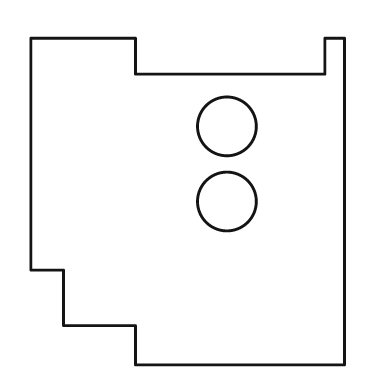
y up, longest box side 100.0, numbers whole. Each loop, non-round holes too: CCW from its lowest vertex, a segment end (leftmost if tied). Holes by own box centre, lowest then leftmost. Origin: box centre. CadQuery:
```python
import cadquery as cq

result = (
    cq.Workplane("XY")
    .moveTo(-16.0, -50.0)
    .lineTo(48.0, -50.0)
    .lineTo(48.0, 50.0)
    .lineTo(42.0, 50.0)
    .lineTo(42.0, 39.0)
    .lineTo(-16.0, 39.0)
    .lineTo(-16.0, 50.0)
    .lineTo(-48.0, 50.0)
    .lineTo(-48.0, -21.0)
    .lineTo(-38.0, -21.0)
    .lineTo(-38.0, -38.0)
    .lineTo(-16.0, -38.0)
    .close()
    .moveTo(12.0, 0.0)
    .circle(9.0)
    .moveTo(12.0, 23.0)
    .circle(9.0)
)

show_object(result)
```